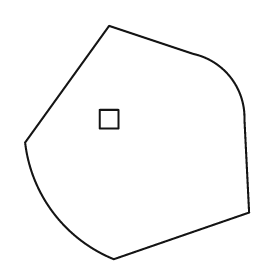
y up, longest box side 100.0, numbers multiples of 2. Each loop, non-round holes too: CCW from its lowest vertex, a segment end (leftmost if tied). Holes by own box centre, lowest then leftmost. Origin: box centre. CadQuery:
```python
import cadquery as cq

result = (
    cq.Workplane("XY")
    .moveTo(-10.0, -50.0)
    .lineTo(48.0, -30.0)
    .lineTo(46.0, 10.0)
    .threePointArc((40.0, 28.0), (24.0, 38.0))
    .lineTo(-12.0, 50.0)
    .lineTo(-48.0, 0.0)
    .threePointArc((-36.0, -30.0), (-10.0, -50.0))
    .close()
    .moveTo(-16.0, 6.0)
    .lineTo(-8.0, 6.0)
    .lineTo(-8.0, 14.0)
    .lineTo(-16.0, 14.0)
    .close()
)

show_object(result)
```